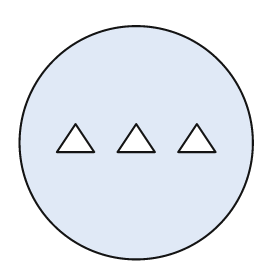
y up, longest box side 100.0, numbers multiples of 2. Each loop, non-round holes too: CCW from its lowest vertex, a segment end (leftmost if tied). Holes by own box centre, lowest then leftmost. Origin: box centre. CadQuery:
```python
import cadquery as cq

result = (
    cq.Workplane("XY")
    .moveTo(0.0, 0.0)
    .circle(50.0)
    .moveTo(-34.0, -4.0)
    .lineTo(-18.0, -4.0)
    .lineTo(-26.0, 8.0)
    .close()
    .moveTo(-8.0, -4.0)
    .lineTo(8.0, -4.0)
    .lineTo(0.0, 8.0)
    .close()
    .moveTo(18.0, -4.0)
    .lineTo(34.0, -4.0)
    .lineTo(26.0, 8.0)
    .close()
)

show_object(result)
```